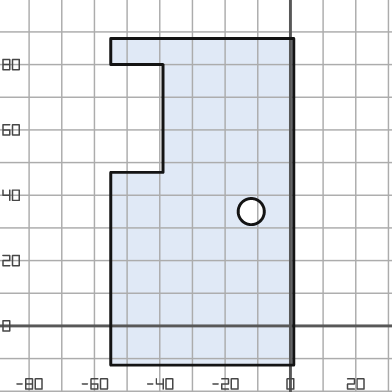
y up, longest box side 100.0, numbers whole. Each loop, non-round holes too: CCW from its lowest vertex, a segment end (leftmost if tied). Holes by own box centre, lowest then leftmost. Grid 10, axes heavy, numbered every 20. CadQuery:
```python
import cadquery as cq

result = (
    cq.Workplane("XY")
    .moveTo(-55.0, -12.0)
    .lineTo(1.0, -12.0)
    .lineTo(1.0, 88.0)
    .lineTo(-55.0, 88.0)
    .lineTo(-55.0, 80.0)
    .lineTo(-39.0, 80.0)
    .lineTo(-39.0, 47.0)
    .lineTo(-55.0, 47.0)
    .close()
    .moveTo(-12.0, 35.0)
    .circle(4.0)
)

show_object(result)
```